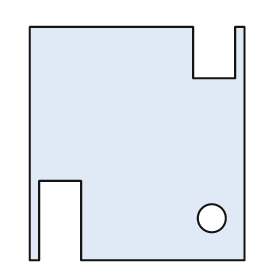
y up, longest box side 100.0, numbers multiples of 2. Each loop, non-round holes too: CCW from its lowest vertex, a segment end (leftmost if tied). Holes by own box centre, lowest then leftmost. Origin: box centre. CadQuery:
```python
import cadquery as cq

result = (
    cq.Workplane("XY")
    .moveTo(-46.0, -50.0)
    .lineTo(-42.0, -50.0)
    .lineTo(-42.0, -16.0)
    .lineTo(-24.0, -16.0)
    .lineTo(-24.0, -50.0)
    .lineTo(46.0, -50.0)
    .lineTo(46.0, 50.0)
    .lineTo(42.0, 50.0)
    .lineTo(42.0, 28.0)
    .lineTo(24.0, 28.0)
    .lineTo(24.0, 50.0)
    .lineTo(-46.0, 50.0)
    .close()
    .moveTo(32.0, -32.0)
    .circle(6.0)
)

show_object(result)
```